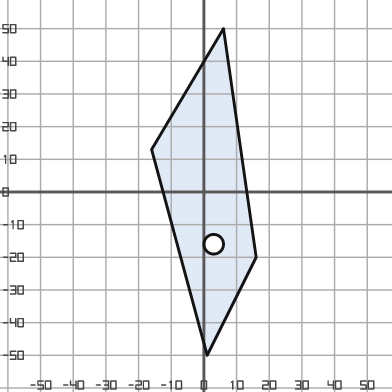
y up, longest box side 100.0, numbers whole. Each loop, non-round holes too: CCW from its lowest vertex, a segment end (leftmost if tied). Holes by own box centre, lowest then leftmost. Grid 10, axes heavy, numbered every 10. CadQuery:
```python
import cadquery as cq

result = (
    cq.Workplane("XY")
    .moveTo(1.0, -50.0)
    .lineTo(16.0, -20.0)
    .lineTo(6.0, 50.0)
    .lineTo(-16.0, 13.0)
    .close()
    .moveTo(3.0, -16.0)
    .circle(3.0)
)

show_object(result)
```